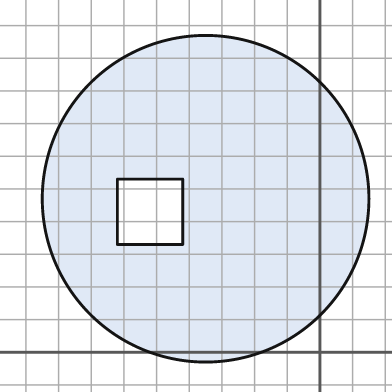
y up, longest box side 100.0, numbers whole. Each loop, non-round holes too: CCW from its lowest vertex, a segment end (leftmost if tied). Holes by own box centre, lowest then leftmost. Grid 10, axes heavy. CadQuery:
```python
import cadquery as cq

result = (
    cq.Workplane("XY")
    .moveTo(-35.0, 47.0)
    .circle(50.0)
    .moveTo(-62.0, 33.0)
    .lineTo(-42.0, 33.0)
    .lineTo(-42.0, 53.0)
    .lineTo(-62.0, 53.0)
    .close()
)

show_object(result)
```